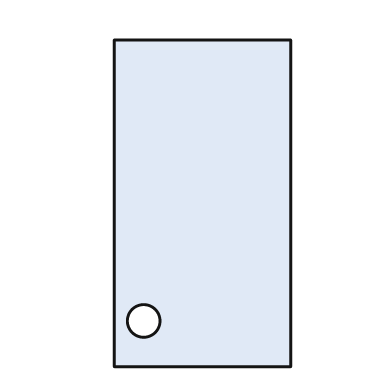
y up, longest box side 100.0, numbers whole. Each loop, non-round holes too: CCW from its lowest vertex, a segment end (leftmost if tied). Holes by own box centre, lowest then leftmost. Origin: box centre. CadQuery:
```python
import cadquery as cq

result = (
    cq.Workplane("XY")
    .moveTo(-27.0, -50.0)
    .lineTo(27.0, -50.0)
    .lineTo(27.0, 50.0)
    .lineTo(-27.0, 50.0)
    .close()
    .moveTo(-18.0, -36.0)
    .circle(5.0)
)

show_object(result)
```